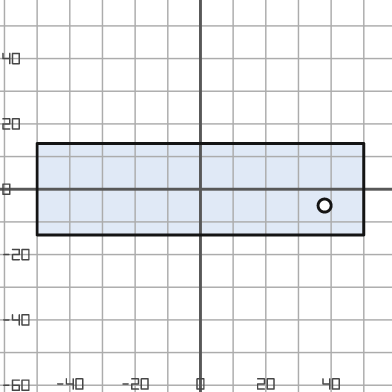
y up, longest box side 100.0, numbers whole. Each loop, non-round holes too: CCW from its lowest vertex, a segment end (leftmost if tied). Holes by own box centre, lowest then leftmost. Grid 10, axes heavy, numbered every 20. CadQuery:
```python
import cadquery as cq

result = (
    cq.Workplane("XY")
    .moveTo(-50.0, -14.0)
    .lineTo(50.0, -14.0)
    .lineTo(50.0, 14.0)
    .lineTo(-50.0, 14.0)
    .close()
    .moveTo(38.0, -5.0)
    .circle(2.0)
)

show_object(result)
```